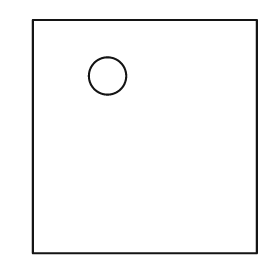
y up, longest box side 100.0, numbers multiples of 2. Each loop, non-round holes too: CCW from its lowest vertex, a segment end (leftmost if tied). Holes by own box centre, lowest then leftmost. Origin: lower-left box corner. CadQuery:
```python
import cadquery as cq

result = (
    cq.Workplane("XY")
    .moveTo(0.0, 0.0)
    .lineTo(96.0, 0.0)
    .lineTo(96.0, 100.0)
    .lineTo(0.0, 100.0)
    .close()
    .moveTo(32.0, 76.0)
    .circle(8.0)
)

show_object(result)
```